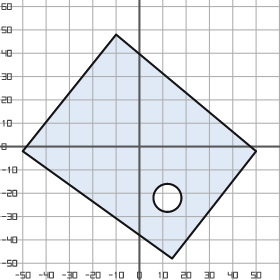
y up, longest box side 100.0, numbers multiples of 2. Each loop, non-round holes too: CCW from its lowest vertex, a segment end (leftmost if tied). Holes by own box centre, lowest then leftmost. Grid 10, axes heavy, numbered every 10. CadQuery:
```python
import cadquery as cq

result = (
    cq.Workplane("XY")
    .moveTo(14.0, -48.0)
    .lineTo(50.0, -2.0)
    .lineTo(-10.0, 48.0)
    .lineTo(-50.0, -2.0)
    .close()
    .moveTo(12.0, -22.0)
    .circle(6.0)
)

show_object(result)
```